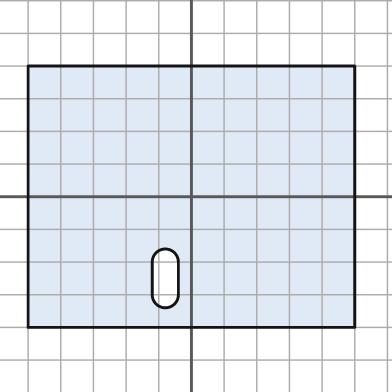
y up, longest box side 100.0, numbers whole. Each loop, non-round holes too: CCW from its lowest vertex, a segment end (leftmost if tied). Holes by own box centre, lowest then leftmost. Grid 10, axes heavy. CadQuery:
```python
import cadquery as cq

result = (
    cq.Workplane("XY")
    .moveTo(-50.0, -40.0)
    .lineTo(50.0, -40.0)
    .lineTo(50.0, 40.0)
    .lineTo(-50.0, 40.0)
    .close()
    .moveTo(-12.0, -30.0)
    .threePointArc((-8.0, -34.0), (-4.0, -30.0))
    .lineTo(-4.0, -20.0)
    .threePointArc((-8.0, -16.0), (-12.0, -20.0))
    .close()
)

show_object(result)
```